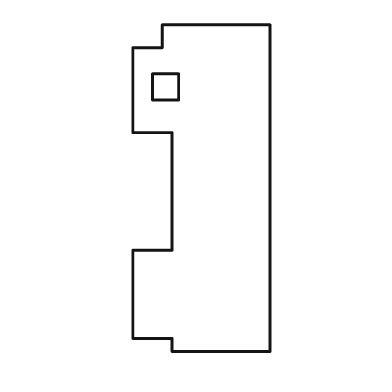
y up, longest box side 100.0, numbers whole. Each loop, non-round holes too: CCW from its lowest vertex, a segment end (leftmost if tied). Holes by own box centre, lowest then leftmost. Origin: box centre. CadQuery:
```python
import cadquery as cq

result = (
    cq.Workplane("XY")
    .moveTo(-9.0, -50.0)
    .lineTo(21.0, -50.0)
    .lineTo(21.0, 50.0)
    .lineTo(-12.0, 50.0)
    .lineTo(-12.0, 43.0)
    .lineTo(-21.0, 43.0)
    .lineTo(-21.0, 17.0)
    .lineTo(-9.0, 17.0)
    .lineTo(-9.0, -19.0)
    .lineTo(-21.0, -19.0)
    .lineTo(-21.0, -46.0)
    .lineTo(-9.0, -46.0)
    .close()
    .moveTo(-15.0, 27.0)
    .lineTo(-7.0, 27.0)
    .lineTo(-7.0, 35.0)
    .lineTo(-15.0, 35.0)
    .close()
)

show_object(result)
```